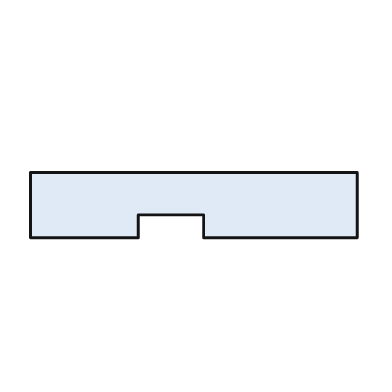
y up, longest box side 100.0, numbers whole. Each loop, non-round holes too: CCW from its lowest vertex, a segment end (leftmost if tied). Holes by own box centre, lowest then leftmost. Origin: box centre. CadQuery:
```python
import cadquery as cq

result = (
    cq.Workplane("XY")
    .moveTo(-50.0, -10.0)
    .lineTo(-17.0, -10.0)
    .lineTo(-17.0, -3.0)
    .lineTo(3.0, -3.0)
    .lineTo(3.0, -10.0)
    .lineTo(50.0, -10.0)
    .lineTo(50.0, 10.0)
    .lineTo(-50.0, 10.0)
    .close()
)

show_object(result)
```